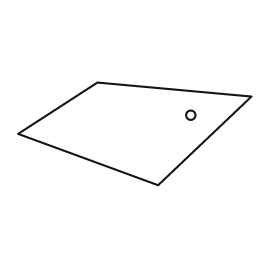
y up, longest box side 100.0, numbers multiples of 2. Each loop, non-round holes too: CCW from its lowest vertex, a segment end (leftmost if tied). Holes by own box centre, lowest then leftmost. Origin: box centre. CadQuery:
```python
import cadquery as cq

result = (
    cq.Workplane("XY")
    .moveTo(10.0, -22.0)
    .lineTo(50.0, 16.0)
    .lineTo(-16.0, 22.0)
    .lineTo(-50.0, 0.0)
    .close()
    .moveTo(24.0, 8.0)
    .circle(2.0)
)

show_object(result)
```